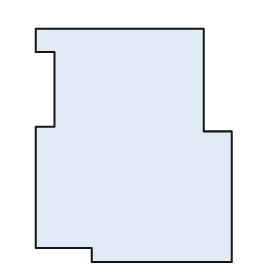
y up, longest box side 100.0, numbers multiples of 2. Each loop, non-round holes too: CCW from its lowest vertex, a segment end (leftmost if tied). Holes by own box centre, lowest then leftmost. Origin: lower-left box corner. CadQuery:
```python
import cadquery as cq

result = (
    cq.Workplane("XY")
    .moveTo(24.0, 0.0)
    .lineTo(84.0, 0.0)
    .lineTo(84.0, 56.0)
    .lineTo(72.0, 56.0)
    .lineTo(72.0, 100.0)
    .lineTo(0.0, 100.0)
    .lineTo(0.0, 90.0)
    .lineTo(8.0, 90.0)
    .lineTo(8.0, 58.0)
    .lineTo(0.0, 58.0)
    .lineTo(0.0, 6.0)
    .lineTo(24.0, 6.0)
    .close()
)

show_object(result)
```